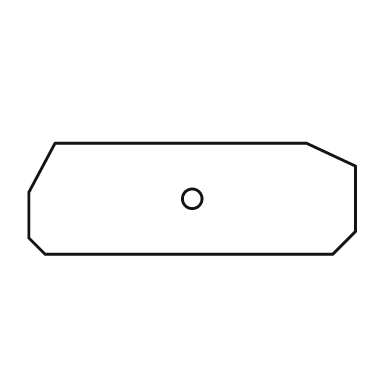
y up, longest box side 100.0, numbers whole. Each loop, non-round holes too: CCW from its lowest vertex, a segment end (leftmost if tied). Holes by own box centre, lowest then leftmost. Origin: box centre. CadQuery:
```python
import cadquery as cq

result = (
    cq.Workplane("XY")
    .moveTo(-45.0, -17.0)
    .lineTo(43.0, -17.0)
    .lineTo(50.0, -10.0)
    .lineTo(50.0, 10.0)
    .lineTo(35.0, 17.0)
    .lineTo(-42.0, 17.0)
    .lineTo(-50.0, 2.0)
    .lineTo(-50.0, -12.0)
    .close()
    .moveTo(0.0, 0.0)
    .circle(3.0)
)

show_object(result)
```